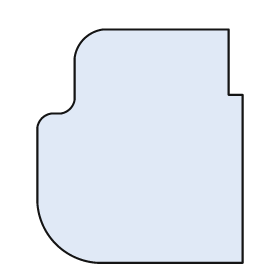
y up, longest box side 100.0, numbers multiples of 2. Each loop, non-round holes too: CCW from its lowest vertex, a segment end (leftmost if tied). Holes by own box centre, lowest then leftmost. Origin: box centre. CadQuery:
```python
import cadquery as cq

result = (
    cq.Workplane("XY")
    .moveTo(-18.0, -50.0)
    .lineTo(44.0, -50.0)
    .lineTo(44.0, 22.0)
    .lineTo(38.0, 22.0)
    .lineTo(38.0, 50.0)
    .lineTo(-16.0, 50.0)
    .threePointArc((-24.0, 46.0), (-28.0, 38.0))
    .lineTo(-28.0, 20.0)
    .threePointArc((-30.0, 16.0), (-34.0, 14.0))
    .lineTo(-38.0, 14.0)
    .threePointArc((-42.0, 12.0), (-44.0, 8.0))
    .lineTo(-44.0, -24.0)
    .threePointArc((-36.0, -42.0), (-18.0, -50.0))
    .close()
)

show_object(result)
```